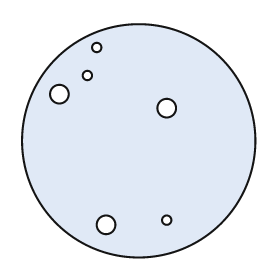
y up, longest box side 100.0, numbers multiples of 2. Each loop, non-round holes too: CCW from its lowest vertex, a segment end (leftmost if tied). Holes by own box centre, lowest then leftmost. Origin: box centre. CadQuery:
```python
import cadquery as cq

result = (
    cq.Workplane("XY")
    .moveTo(0.0, 0.0)
    .circle(50.0)
    .moveTo(-14.0, -36.0)
    .circle(4.0)
    .moveTo(12.0, -34.0)
    .circle(2.0)
    .moveTo(12.0, 14.0)
    .circle(4.0)
    .moveTo(-34.0, 20.0)
    .circle(4.0)
    .moveTo(-22.0, 28.0)
    .circle(2.0)
    .moveTo(-18.0, 40.0)
    .circle(2.0)
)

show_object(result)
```